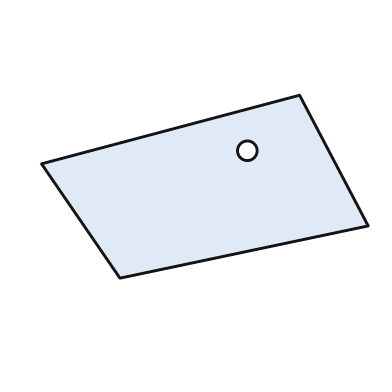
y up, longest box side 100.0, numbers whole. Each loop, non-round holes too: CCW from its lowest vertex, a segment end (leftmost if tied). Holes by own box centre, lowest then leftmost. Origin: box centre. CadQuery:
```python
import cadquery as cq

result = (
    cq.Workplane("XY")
    .moveTo(-26.0, -28.0)
    .lineTo(50.0, -12.0)
    .lineTo(29.0, 28.0)
    .lineTo(-50.0, 7.0)
    .close()
    .moveTo(13.0, 11.0)
    .circle(3.0)
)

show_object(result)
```